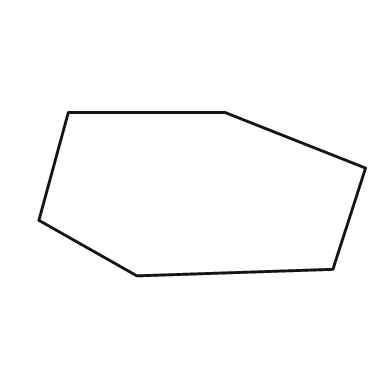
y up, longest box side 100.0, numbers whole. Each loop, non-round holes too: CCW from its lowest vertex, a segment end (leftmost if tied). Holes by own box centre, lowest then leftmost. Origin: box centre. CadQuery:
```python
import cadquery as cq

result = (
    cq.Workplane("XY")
    .moveTo(-20.0, -25.0)
    .lineTo(40.0, -23.0)
    .lineTo(50.0, 8.0)
    .lineTo(7.0, 25.0)
    .lineTo(-41.0, 25.0)
    .lineTo(-50.0, -8.0)
    .close()
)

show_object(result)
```